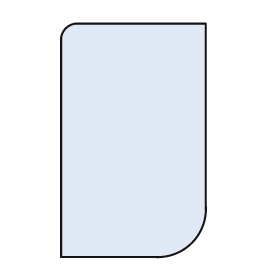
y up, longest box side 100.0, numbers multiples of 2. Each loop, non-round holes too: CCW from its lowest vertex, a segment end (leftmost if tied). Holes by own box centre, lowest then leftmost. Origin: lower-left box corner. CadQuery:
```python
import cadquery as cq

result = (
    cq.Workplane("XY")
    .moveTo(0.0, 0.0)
    .lineTo(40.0, 0.0)
    .threePointArc((56.0, 6.0), (62.0, 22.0))
    .lineTo(62.0, 100.0)
    .lineTo(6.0, 100.0)
    .threePointArc((2.0, 98.0), (0.0, 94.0))
    .close()
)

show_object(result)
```